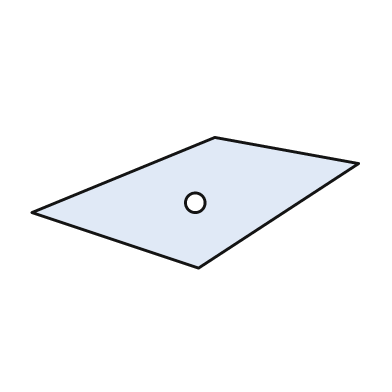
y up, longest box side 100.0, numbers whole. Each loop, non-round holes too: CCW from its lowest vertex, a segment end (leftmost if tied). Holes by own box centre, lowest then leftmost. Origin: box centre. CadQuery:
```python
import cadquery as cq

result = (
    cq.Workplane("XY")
    .moveTo(1.0, -20.0)
    .lineTo(50.0, 12.0)
    .lineTo(6.0, 20.0)
    .lineTo(-50.0, -3.0)
    .close()
    .moveTo(0.0, 0.0)
    .circle(3.0)
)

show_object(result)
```